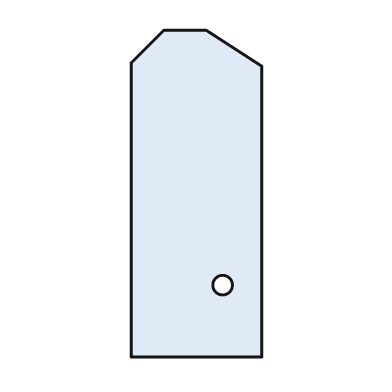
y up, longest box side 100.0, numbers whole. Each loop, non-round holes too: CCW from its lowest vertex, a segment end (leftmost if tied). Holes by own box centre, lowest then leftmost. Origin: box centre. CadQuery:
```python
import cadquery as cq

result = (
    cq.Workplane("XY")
    .moveTo(-20.0, -50.0)
    .lineTo(20.0, -50.0)
    .lineTo(20.0, 39.0)
    .lineTo(3.0, 50.0)
    .lineTo(-10.0, 50.0)
    .lineTo(-20.0, 40.0)
    .close()
    .moveTo(8.0, -28.0)
    .circle(3.0)
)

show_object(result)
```